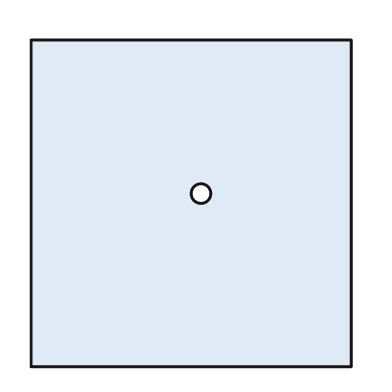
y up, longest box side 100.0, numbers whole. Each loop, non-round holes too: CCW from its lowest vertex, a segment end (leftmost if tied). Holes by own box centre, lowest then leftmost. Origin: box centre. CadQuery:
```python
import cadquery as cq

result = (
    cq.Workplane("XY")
    .moveTo(-49.0, -50.0)
    .lineTo(49.0, -50.0)
    .lineTo(49.0, 50.0)
    .lineTo(-49.0, 50.0)
    .close()
    .moveTo(3.0, 3.0)
    .circle(3.0)
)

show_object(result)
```